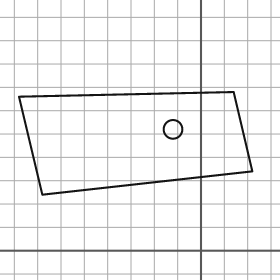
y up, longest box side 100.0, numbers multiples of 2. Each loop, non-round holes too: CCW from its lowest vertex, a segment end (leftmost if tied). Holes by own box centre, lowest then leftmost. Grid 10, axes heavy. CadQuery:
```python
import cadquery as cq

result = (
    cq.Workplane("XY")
    .moveTo(-68.0, 24.0)
    .lineTo(22.0, 34.0)
    .lineTo(14.0, 68.0)
    .lineTo(-78.0, 66.0)
    .close()
    .moveTo(-12.0, 52.0)
    .circle(4.0)
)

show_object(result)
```